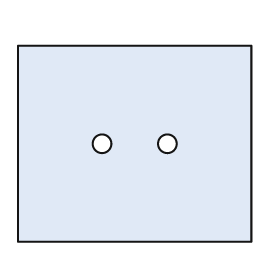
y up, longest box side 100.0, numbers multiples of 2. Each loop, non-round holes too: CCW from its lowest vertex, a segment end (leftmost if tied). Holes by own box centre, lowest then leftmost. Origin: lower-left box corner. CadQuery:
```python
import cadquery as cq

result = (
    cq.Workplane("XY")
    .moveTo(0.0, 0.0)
    .lineTo(100.0, 0.0)
    .lineTo(100.0, 84.0)
    .lineTo(0.0, 84.0)
    .close()
    .moveTo(36.0, 42.0)
    .circle(4.0)
    .moveTo(64.0, 42.0)
    .circle(4.0)
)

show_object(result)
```